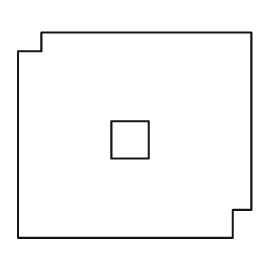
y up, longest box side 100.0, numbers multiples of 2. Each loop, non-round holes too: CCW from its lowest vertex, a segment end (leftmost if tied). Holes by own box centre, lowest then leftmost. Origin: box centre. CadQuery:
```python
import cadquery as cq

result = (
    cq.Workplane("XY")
    .moveTo(-50.0, -44.0)
    .lineTo(42.0, -44.0)
    .lineTo(42.0, -32.0)
    .lineTo(50.0, -32.0)
    .lineTo(50.0, 44.0)
    .lineTo(-40.0, 44.0)
    .lineTo(-40.0, 36.0)
    .lineTo(-50.0, 36.0)
    .close()
    .moveTo(-10.0, -10.0)
    .lineTo(6.0, -10.0)
    .lineTo(6.0, 6.0)
    .lineTo(-10.0, 6.0)
    .close()
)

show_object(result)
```